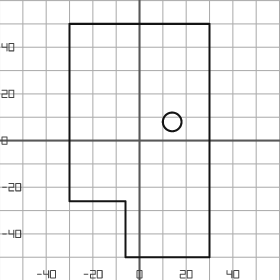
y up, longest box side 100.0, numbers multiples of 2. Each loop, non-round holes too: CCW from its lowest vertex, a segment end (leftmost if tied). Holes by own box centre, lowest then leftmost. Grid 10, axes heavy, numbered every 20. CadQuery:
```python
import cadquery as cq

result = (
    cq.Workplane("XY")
    .moveTo(-6.0, -50.0)
    .lineTo(30.0, -50.0)
    .lineTo(30.0, 50.0)
    .lineTo(-30.0, 50.0)
    .lineTo(-30.0, -26.0)
    .lineTo(-6.0, -26.0)
    .close()
    .moveTo(14.0, 8.0)
    .circle(4.0)
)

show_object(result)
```